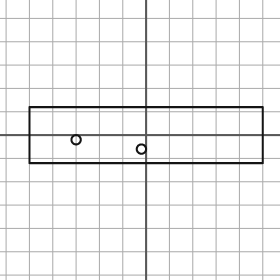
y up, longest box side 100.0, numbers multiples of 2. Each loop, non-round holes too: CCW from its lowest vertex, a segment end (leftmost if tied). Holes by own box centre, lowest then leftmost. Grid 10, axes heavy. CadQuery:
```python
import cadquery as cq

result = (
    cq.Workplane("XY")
    .moveTo(-50.0, -12.0)
    .lineTo(50.0, -12.0)
    .lineTo(50.0, 12.0)
    .lineTo(-50.0, 12.0)
    .close()
    .moveTo(-2.0, -6.0)
    .circle(2.0)
    .moveTo(-30.0, -2.0)
    .circle(2.0)
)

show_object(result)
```